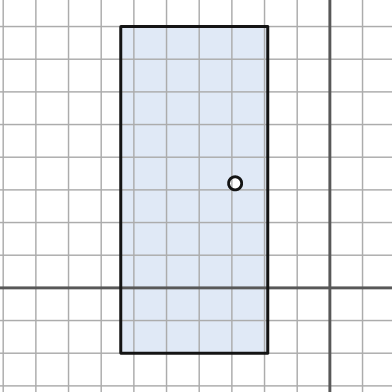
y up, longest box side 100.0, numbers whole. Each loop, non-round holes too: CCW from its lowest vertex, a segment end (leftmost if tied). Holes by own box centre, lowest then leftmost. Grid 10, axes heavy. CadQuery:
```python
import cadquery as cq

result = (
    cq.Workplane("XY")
    .moveTo(-64.0, -20.0)
    .lineTo(-19.0, -20.0)
    .lineTo(-19.0, 80.0)
    .lineTo(-64.0, 80.0)
    .close()
    .moveTo(-29.0, 32.0)
    .circle(2.0)
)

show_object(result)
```